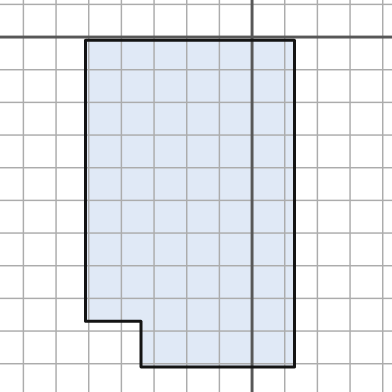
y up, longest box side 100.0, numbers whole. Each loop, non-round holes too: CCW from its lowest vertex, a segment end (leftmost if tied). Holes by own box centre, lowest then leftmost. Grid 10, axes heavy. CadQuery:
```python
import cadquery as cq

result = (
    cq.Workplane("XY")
    .moveTo(-34.0, -101.0)
    .lineTo(13.0, -101.0)
    .lineTo(13.0, -1.0)
    .lineTo(-51.0, -1.0)
    .lineTo(-51.0, -87.0)
    .lineTo(-34.0, -87.0)
    .close()
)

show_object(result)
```